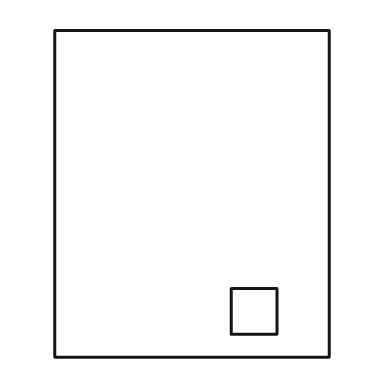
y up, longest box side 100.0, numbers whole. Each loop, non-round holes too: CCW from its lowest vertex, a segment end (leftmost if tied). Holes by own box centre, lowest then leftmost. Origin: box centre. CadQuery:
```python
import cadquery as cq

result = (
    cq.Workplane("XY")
    .moveTo(-42.0, -50.0)
    .lineTo(42.0, -50.0)
    .lineTo(42.0, 50.0)
    .lineTo(-42.0, 50.0)
    .close()
    .moveTo(12.0, -43.0)
    .lineTo(26.0, -43.0)
    .lineTo(26.0, -29.0)
    .lineTo(12.0, -29.0)
    .close()
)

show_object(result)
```